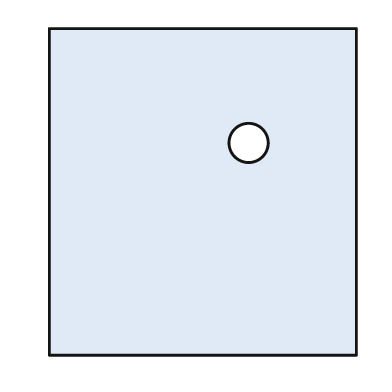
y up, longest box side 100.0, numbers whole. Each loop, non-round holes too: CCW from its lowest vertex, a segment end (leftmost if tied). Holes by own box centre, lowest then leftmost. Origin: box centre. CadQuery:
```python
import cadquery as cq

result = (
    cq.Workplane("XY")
    .moveTo(-47.0, -50.0)
    .lineTo(47.0, -50.0)
    .lineTo(47.0, 50.0)
    .lineTo(-47.0, 50.0)
    .close()
    .moveTo(14.0, 15.0)
    .circle(6.0)
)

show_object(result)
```